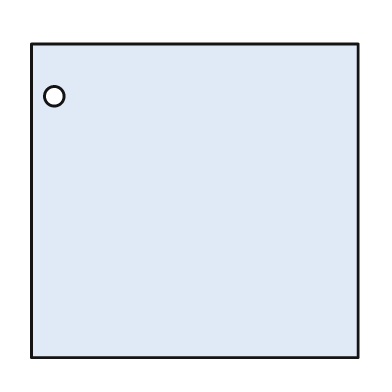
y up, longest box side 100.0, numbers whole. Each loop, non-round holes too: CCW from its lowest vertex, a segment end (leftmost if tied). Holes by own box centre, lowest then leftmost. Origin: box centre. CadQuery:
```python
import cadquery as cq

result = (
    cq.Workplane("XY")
    .moveTo(-50.0, -48.0)
    .lineTo(50.0, -48.0)
    .lineTo(50.0, 48.0)
    .lineTo(-50.0, 48.0)
    .close()
    .moveTo(-43.0, 32.0)
    .circle(3.0)
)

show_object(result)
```